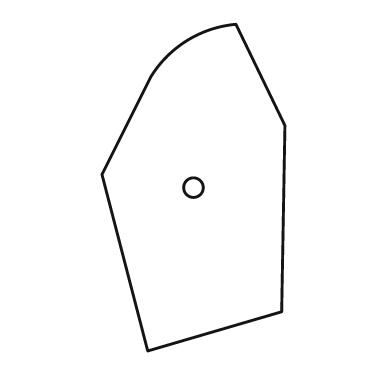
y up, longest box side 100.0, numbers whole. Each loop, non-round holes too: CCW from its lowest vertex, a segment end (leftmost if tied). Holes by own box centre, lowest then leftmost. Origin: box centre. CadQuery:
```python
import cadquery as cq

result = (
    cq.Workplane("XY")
    .moveTo(-14.0, -50.0)
    .lineTo(27.0, -38.0)
    .lineTo(28.0, 19.0)
    .lineTo(13.0, 50.0)
    .threePointArc((-2.0, 45.0), (-13.0, 34.0))
    .lineTo(-28.0, 4.0)
    .close()
    .moveTo(0.0, 0.0)
    .circle(3.0)
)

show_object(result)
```